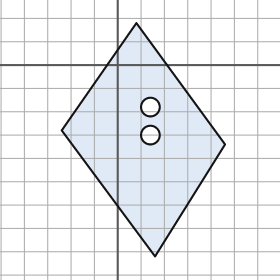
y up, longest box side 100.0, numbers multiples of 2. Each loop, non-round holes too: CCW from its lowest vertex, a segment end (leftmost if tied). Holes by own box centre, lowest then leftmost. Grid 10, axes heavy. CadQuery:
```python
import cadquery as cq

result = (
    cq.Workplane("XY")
    .moveTo(16.0, -82.0)
    .lineTo(46.0, -34.0)
    .lineTo(8.0, 18.0)
    .lineTo(-24.0, -28.0)
    .close()
    .moveTo(14.0, -30.0)
    .circle(4.0)
    .moveTo(14.0, -18.0)
    .circle(4.0)
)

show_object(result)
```